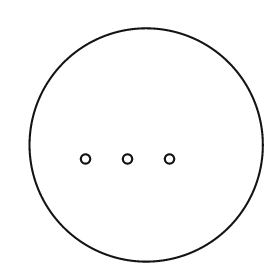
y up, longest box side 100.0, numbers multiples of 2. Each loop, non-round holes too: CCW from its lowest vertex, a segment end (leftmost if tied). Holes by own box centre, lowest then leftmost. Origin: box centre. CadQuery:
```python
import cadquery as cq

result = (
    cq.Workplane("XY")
    .moveTo(0.0, 0.0)
    .circle(50.0)
    .moveTo(-26.0, -6.0)
    .circle(2.0)
    .moveTo(-8.0, -6.0)
    .circle(2.0)
    .moveTo(10.0, -6.0)
    .circle(2.0)
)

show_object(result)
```